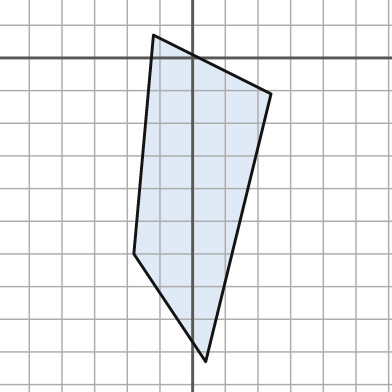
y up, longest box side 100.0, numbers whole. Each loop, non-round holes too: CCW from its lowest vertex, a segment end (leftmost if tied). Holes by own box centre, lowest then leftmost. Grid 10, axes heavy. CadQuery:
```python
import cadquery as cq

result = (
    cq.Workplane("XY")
    .moveTo(4.0, -93.0)
    .lineTo(24.0, -11.0)
    .lineTo(-12.0, 7.0)
    .lineTo(-18.0, -60.0)
    .close()
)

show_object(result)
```